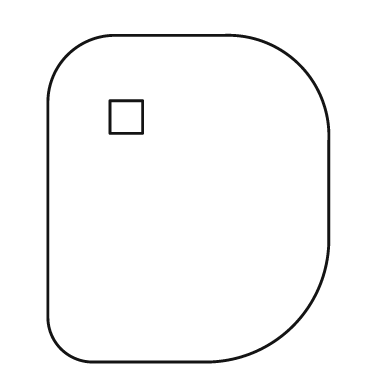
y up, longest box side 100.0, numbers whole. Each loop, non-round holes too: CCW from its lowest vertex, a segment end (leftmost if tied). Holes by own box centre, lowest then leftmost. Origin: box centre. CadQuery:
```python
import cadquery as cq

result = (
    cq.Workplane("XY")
    .moveTo(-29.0, -50.0)
    .lineTo(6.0, -50.0)
    .threePointArc((32.0, -39.0), (43.0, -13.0))
    .lineTo(43.0, 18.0)
    .threePointArc((34.0, 41.0), (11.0, 50.0))
    .lineTo(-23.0, 50.0)
    .threePointArc((-37.0, 44.0), (-43.0, 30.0))
    .lineTo(-43.0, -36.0)
    .threePointArc((-39.0, -46.0), (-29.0, -50.0))
    .close()
    .moveTo(-24.0, 20.0)
    .lineTo(-14.0, 20.0)
    .lineTo(-14.0, 30.0)
    .lineTo(-24.0, 30.0)
    .close()
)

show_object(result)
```